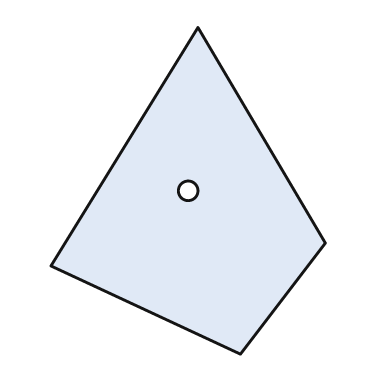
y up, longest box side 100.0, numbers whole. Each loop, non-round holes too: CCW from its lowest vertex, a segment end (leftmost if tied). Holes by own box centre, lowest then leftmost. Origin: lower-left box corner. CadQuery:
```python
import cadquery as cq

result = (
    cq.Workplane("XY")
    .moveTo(58.0, 0.0)
    .lineTo(84.0, 34.0)
    .lineTo(45.0, 100.0)
    .lineTo(0.0, 27.0)
    .close()
    .moveTo(42.0, 50.0)
    .circle(3.0)
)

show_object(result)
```